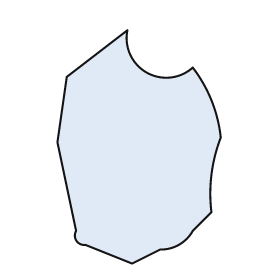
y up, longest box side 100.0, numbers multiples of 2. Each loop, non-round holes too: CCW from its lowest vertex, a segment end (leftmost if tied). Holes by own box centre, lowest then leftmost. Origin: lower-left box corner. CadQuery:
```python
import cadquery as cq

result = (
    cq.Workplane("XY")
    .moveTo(32.0, 0.0)
    .lineTo(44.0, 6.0)
    .threePointArc((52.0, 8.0), (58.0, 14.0))
    .lineTo(66.0, 22.0)
    .threePointArc((66.0, 38.0), (70.0, 54.0))
    .threePointArc((66.0, 70.0), (58.0, 84.0))
    .threePointArc((38.0, 82.0), (30.0, 100.0))
    .lineTo(4.0, 80.0)
    .lineTo(0.0, 52.0)
    .lineTo(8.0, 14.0)
    .threePointArc((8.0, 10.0), (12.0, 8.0))
    .close()
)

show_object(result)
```